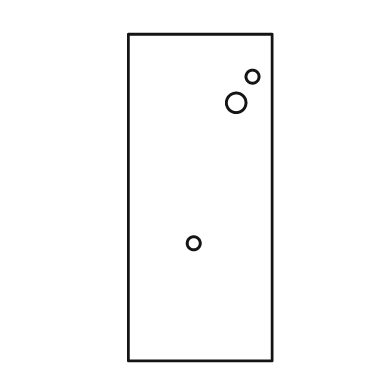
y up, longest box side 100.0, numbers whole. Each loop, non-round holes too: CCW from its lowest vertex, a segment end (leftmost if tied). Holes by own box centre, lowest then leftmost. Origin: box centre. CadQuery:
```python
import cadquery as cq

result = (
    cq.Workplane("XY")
    .moveTo(-22.0, -50.0)
    .lineTo(22.0, -50.0)
    .lineTo(22.0, 50.0)
    .lineTo(-22.0, 50.0)
    .close()
    .moveTo(-2.0, -14.0)
    .circle(2.0)
    .moveTo(11.0, 29.0)
    .circle(3.0)
    .moveTo(16.0, 37.0)
    .circle(2.0)
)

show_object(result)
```